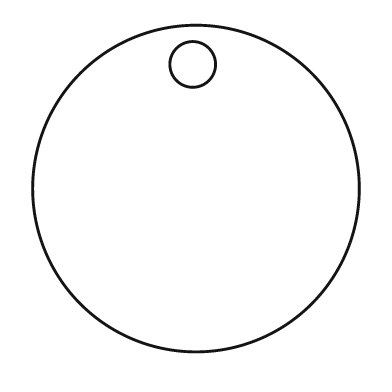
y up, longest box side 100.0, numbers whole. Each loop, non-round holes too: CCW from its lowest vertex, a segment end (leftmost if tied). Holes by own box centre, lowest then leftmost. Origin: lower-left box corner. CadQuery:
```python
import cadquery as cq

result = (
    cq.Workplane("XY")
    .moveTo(50.0, 50.0)
    .circle(50.0)
    .moveTo(49.0, 88.0)
    .circle(7.0)
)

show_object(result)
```